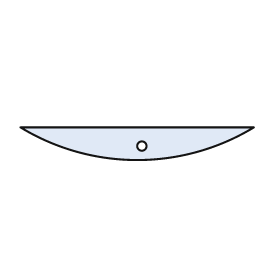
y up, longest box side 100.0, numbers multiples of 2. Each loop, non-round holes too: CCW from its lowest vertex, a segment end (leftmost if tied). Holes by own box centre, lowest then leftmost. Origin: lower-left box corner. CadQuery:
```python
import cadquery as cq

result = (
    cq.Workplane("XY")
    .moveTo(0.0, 14.0)
    .threePointArc((50.0, 0.0), (100.0, 14.0))
    .close()
    .moveTo(52.0, 6.0)
    .circle(2.0)
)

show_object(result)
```